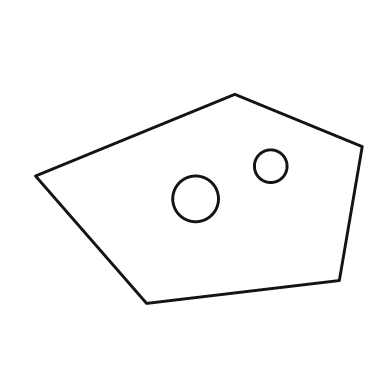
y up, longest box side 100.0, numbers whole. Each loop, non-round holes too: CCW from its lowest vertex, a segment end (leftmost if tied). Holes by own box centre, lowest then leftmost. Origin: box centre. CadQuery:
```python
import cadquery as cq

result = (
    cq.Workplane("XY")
    .moveTo(-16.0, -32.0)
    .lineTo(43.0, -25.0)
    .lineTo(50.0, 16.0)
    .lineTo(11.0, 32.0)
    .lineTo(-50.0, 7.0)
    .close()
    .moveTo(-1.0, 0.0)
    .circle(7.0)
    .moveTo(22.0, 10.0)
    .circle(5.0)
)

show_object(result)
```